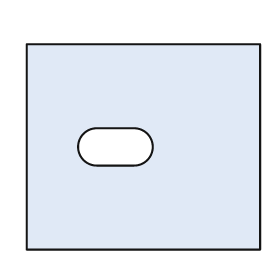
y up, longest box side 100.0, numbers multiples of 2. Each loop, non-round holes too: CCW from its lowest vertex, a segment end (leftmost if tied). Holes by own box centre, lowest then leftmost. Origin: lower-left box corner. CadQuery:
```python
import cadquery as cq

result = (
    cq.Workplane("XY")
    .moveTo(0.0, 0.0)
    .lineTo(100.0, 0.0)
    .lineTo(100.0, 88.0)
    .lineTo(0.0, 88.0)
    .close()
    .moveTo(30.0, 36.0)
    .lineTo(46.0, 36.0)
    .threePointArc((54.0, 44.0), (46.0, 52.0))
    .lineTo(30.0, 52.0)
    .threePointArc((22.0, 44.0), (30.0, 36.0))
    .close()
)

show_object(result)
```